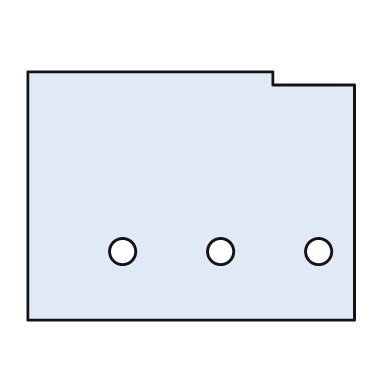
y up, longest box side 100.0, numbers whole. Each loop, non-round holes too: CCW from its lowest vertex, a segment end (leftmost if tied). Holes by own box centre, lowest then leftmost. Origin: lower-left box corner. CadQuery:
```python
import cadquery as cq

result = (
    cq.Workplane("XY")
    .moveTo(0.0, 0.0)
    .lineTo(100.0, 0.0)
    .lineTo(100.0, 72.0)
    .lineTo(75.0, 72.0)
    .lineTo(75.0, 76.0)
    .lineTo(0.0, 76.0)
    .close()
    .moveTo(29.0, 21.0)
    .circle(4.0)
    .moveTo(59.0, 21.0)
    .circle(4.0)
    .moveTo(89.0, 21.0)
    .circle(4.0)
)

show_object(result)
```